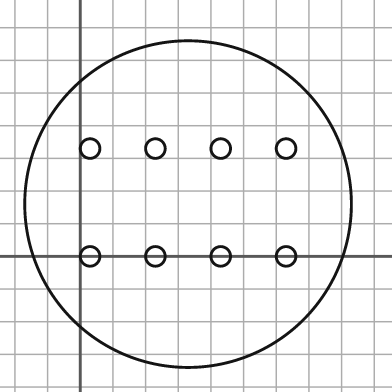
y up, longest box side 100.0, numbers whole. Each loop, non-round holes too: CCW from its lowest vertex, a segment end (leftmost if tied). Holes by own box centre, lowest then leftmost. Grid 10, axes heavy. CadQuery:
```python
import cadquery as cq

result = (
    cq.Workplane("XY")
    .moveTo(33.0, 16.0)
    .circle(50.0)
    .moveTo(3.0, 0.0)
    .circle(3.0)
    .moveTo(23.0, 0.0)
    .circle(3.0)
    .moveTo(43.0, 0.0)
    .circle(3.0)
    .moveTo(63.0, 0.0)
    .circle(3.0)
    .moveTo(3.0, 33.0)
    .circle(3.0)
    .moveTo(23.0, 33.0)
    .circle(3.0)
    .moveTo(43.0, 33.0)
    .circle(3.0)
    .moveTo(63.0, 33.0)
    .circle(3.0)
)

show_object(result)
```